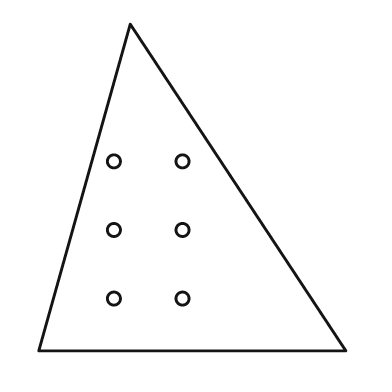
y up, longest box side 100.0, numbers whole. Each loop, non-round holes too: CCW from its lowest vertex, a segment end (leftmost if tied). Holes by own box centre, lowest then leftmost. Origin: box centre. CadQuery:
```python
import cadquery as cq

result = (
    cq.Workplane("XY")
    .moveTo(-47.0, -50.0)
    .lineTo(47.0, -50.0)
    .lineTo(-19.0, 50.0)
    .close()
    .moveTo(-24.0, -34.0)
    .circle(2.0)
    .moveTo(-3.0, -34.0)
    .circle(2.0)
    .moveTo(-24.0, -13.0)
    .circle(2.0)
    .moveTo(-3.0, -13.0)
    .circle(2.0)
    .moveTo(-24.0, 8.0)
    .circle(2.0)
    .moveTo(-3.0, 8.0)
    .circle(2.0)
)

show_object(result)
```